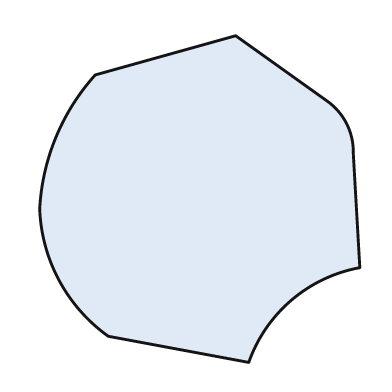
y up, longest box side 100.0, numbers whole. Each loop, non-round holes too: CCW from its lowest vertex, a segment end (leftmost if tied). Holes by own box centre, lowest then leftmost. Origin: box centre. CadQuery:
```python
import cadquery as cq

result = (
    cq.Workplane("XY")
    .moveTo(15.0, -50.0)
    .threePointArc((28.0, -31.0), (49.0, -21.0))
    .lineTo(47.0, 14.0)
    .threePointArc((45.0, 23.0), (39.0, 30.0))
    .lineTo(11.0, 50.0)
    .lineTo(-32.0, 38.0)
    .threePointArc((-44.0, 19.0), (-49.0, -3.0))
    .threePointArc((-43.0, -25.0), (-28.0, -42.0))
    .close()
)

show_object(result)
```